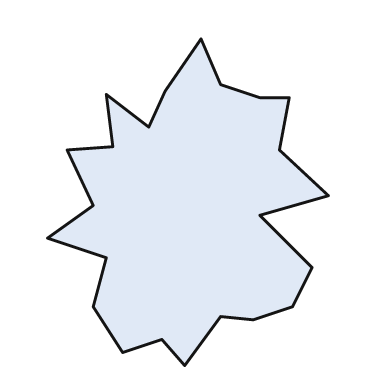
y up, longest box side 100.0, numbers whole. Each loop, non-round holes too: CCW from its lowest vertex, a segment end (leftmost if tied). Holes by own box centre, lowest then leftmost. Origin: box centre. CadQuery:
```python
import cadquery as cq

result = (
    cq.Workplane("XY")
    .moveTo(-1.0, -50.0)
    .lineTo(10.0, -35.0)
    .lineTo(20.0, -36.0)
    .lineTo(32.0, -32.0)
    .lineTo(38.0, -20.0)
    .lineTo(22.0, -4.0)
    .lineTo(43.0, 2.0)
    .lineTo(28.0, 16.0)
    .lineTo(31.0, 32.0)
    .lineTo(22.0, 32.0)
    .lineTo(10.0, 36.0)
    .lineTo(4.0, 50.0)
    .lineTo(-7.0, 34.0)
    .lineTo(-12.0, 23.0)
    .lineTo(-25.0, 33.0)
    .lineTo(-23.0, 17.0)
    .lineTo(-37.0, 16.0)
    .lineTo(-29.0, -1.0)
    .lineTo(-43.0, -11.0)
    .lineTo(-25.0, -17.0)
    .lineTo(-29.0, -32.0)
    .lineTo(-20.0, -46.0)
    .lineTo(-8.0, -42.0)
    .close()
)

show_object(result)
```